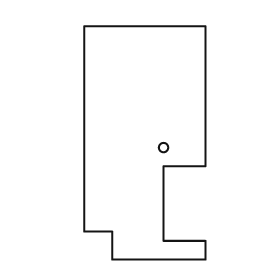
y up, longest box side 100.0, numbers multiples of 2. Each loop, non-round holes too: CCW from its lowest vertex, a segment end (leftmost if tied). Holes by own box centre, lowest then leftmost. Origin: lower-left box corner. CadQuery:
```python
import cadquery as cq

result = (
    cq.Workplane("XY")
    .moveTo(12.0, 0.0)
    .lineTo(52.0, 0.0)
    .lineTo(52.0, 8.0)
    .lineTo(34.0, 8.0)
    .lineTo(34.0, 40.0)
    .lineTo(52.0, 40.0)
    .lineTo(52.0, 100.0)
    .lineTo(0.0, 100.0)
    .lineTo(0.0, 12.0)
    .lineTo(12.0, 12.0)
    .close()
    .moveTo(34.0, 48.0)
    .circle(2.0)
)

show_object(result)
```